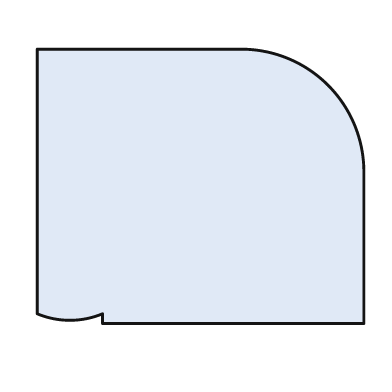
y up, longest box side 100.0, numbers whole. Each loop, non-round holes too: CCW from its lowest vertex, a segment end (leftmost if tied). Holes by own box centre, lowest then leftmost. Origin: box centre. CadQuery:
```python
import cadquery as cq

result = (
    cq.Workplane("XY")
    .moveTo(-30.0, -42.0)
    .lineTo(50.0, -42.0)
    .lineTo(50.0, 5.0)
    .threePointArc((39.0, 31.0), (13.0, 42.0))
    .lineTo(-50.0, 42.0)
    .lineTo(-50.0, -39.0)
    .threePointArc((-40.0, -41.0), (-30.0, -39.0))
    .close()
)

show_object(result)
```